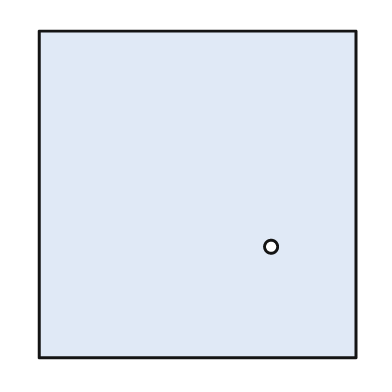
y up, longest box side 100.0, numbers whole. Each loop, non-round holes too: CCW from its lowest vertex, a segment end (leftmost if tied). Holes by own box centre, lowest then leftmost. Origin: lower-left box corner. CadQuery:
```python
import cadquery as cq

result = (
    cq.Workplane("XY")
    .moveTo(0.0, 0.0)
    .lineTo(97.0, 0.0)
    .lineTo(97.0, 100.0)
    .lineTo(0.0, 100.0)
    .close()
    .moveTo(71.0, 34.0)
    .circle(2.0)
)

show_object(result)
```